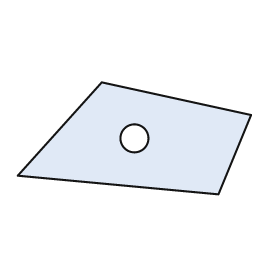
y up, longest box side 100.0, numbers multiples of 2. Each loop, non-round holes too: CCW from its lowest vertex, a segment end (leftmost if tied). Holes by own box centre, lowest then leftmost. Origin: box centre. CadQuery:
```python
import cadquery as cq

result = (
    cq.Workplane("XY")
    .moveTo(36.0, -24.0)
    .lineTo(50.0, 10.0)
    .lineTo(-14.0, 24.0)
    .lineTo(-50.0, -16.0)
    .close()
    .moveTo(0.0, 0.0)
    .circle(6.0)
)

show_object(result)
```